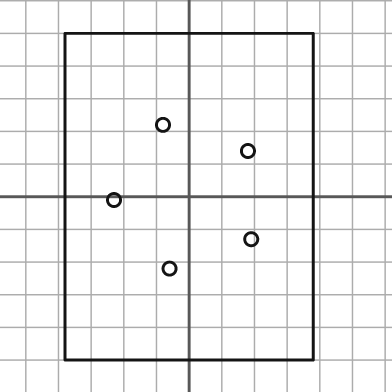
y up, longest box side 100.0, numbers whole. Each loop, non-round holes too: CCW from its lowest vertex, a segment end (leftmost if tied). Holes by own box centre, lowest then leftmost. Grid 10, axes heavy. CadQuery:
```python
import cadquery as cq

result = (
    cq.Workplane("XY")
    .moveTo(-38.0, -50.0)
    .lineTo(38.0, -50.0)
    .lineTo(38.0, 50.0)
    .lineTo(-38.0, 50.0)
    .close()
    .moveTo(-6.0, -22.0)
    .circle(2.0)
    .moveTo(19.0, -13.0)
    .circle(2.0)
    .moveTo(-23.0, -1.0)
    .circle(2.0)
    .moveTo(18.0, 14.0)
    .circle(2.0)
    .moveTo(-8.0, 22.0)
    .circle(2.0)
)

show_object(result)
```